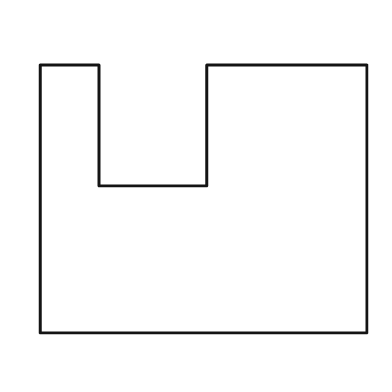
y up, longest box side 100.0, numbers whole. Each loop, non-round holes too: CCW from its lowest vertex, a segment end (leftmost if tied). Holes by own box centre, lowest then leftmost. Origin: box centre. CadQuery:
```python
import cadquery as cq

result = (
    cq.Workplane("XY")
    .moveTo(-50.0, -41.0)
    .lineTo(50.0, -41.0)
    .lineTo(50.0, 41.0)
    .lineTo(1.0, 41.0)
    .lineTo(1.0, 4.0)
    .lineTo(-32.0, 4.0)
    .lineTo(-32.0, 41.0)
    .lineTo(-50.0, 41.0)
    .close()
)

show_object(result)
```